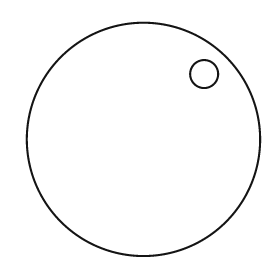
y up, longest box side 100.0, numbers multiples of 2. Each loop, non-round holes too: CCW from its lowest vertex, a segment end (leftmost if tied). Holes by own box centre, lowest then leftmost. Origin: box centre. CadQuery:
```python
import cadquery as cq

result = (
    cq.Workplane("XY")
    .moveTo(0.0, 0.0)
    .circle(50.0)
    .moveTo(26.0, 28.0)
    .circle(6.0)
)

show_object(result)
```